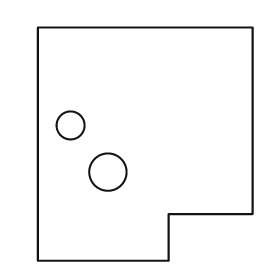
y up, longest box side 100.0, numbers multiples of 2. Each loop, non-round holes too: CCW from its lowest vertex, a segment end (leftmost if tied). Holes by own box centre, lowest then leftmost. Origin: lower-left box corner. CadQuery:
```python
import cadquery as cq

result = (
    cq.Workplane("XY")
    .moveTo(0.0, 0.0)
    .lineTo(56.0, 0.0)
    .lineTo(56.0, 20.0)
    .lineTo(92.0, 20.0)
    .lineTo(92.0, 100.0)
    .lineTo(0.0, 100.0)
    .close()
    .moveTo(30.0, 38.0)
    .circle(8.0)
    .moveTo(14.0, 58.0)
    .circle(6.0)
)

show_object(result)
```